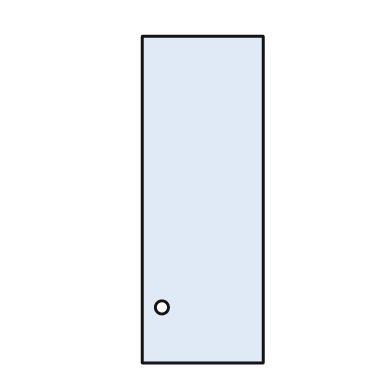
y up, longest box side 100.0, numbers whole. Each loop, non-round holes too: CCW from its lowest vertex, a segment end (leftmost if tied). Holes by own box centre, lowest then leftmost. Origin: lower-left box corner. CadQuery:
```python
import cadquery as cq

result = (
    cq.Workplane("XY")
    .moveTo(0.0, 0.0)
    .lineTo(37.0, 0.0)
    .lineTo(37.0, 100.0)
    .lineTo(0.0, 100.0)
    .close()
    .moveTo(6.0, 17.0)
    .circle(2.0)
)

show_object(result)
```